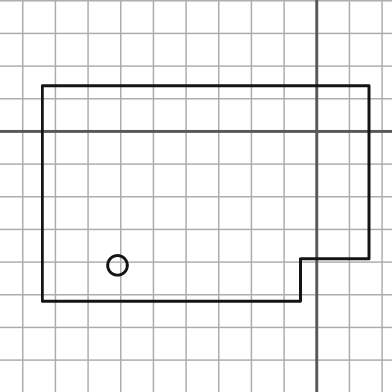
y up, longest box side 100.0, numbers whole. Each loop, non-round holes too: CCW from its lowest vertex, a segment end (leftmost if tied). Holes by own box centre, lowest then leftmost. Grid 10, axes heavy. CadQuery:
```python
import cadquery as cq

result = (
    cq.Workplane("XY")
    .moveTo(-84.0, -52.0)
    .lineTo(-5.0, -52.0)
    .lineTo(-5.0, -39.0)
    .lineTo(16.0, -39.0)
    .lineTo(16.0, 14.0)
    .lineTo(-84.0, 14.0)
    .close()
    .moveTo(-61.0, -41.0)
    .circle(3.0)
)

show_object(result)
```